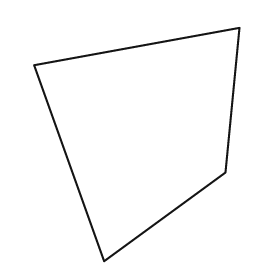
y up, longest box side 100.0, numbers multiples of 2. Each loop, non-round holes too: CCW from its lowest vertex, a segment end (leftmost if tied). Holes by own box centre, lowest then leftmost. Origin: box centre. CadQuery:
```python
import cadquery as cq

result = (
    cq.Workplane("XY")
    .moveTo(-14.0, -50.0)
    .lineTo(38.0, -12.0)
    .lineTo(44.0, 50.0)
    .lineTo(-44.0, 34.0)
    .close()
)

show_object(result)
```